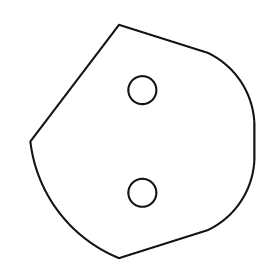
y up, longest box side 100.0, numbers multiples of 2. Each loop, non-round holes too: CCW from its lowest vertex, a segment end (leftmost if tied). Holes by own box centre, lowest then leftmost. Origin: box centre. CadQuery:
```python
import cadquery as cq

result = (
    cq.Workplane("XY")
    .moveTo(-10.0, -50.0)
    .lineTo(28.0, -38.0)
    .threePointArc((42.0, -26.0), (48.0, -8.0))
    .lineTo(48.0, 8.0)
    .threePointArc((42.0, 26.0), (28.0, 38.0))
    .lineTo(-10.0, 50.0)
    .lineTo(-48.0, 0.0)
    .threePointArc((-36.0, -30.0), (-10.0, -50.0))
    .close()
    .moveTo(0.0, -22.0)
    .circle(6.0)
    .moveTo(0.0, 22.0)
    .circle(6.0)
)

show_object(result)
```